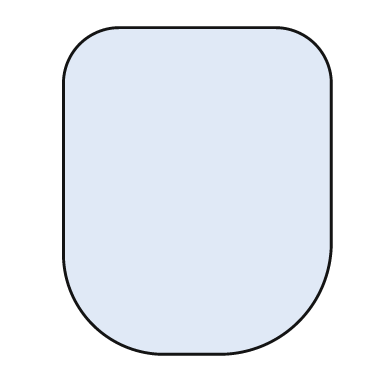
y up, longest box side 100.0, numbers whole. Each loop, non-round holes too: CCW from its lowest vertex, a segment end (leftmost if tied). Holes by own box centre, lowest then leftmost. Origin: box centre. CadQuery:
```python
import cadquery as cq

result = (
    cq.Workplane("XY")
    .moveTo(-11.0, -50.0)
    .lineTo(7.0, -50.0)
    .threePointArc((31.0, -40.0), (41.0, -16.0))
    .lineTo(41.0, 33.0)
    .threePointArc((36.0, 45.0), (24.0, 50.0))
    .lineTo(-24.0, 50.0)
    .threePointArc((-36.0, 45.0), (-41.0, 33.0))
    .lineTo(-41.0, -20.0)
    .threePointArc((-32.0, -41.0), (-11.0, -50.0))
    .close()
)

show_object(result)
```